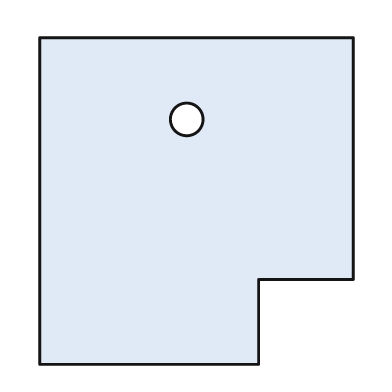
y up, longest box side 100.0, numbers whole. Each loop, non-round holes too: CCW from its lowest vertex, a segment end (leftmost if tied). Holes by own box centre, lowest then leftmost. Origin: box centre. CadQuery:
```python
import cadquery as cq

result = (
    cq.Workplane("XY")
    .moveTo(-48.0, -50.0)
    .lineTo(19.0, -50.0)
    .lineTo(19.0, -24.0)
    .lineTo(48.0, -24.0)
    .lineTo(48.0, 50.0)
    .lineTo(-48.0, 50.0)
    .close()
    .moveTo(-3.0, 25.0)
    .circle(5.0)
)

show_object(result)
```